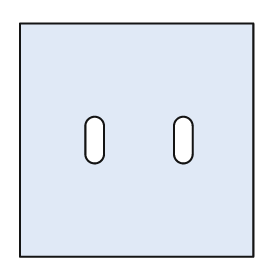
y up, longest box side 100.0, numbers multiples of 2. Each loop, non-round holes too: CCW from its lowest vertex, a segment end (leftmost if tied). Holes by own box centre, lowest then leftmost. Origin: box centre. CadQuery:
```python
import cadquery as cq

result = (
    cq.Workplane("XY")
    .moveTo(-50.0, -50.0)
    .lineTo(50.0, -50.0)
    .lineTo(50.0, 50.0)
    .lineTo(-50.0, 50.0)
    .close()
    .moveTo(-22.0, -6.0)
    .threePointArc((-18.0, -10.0), (-14.0, -6.0))
    .lineTo(-14.0, 6.0)
    .threePointArc((-18.0, 10.0), (-22.0, 6.0))
    .close()
    .moveTo(16.0, -6.0)
    .threePointArc((20.0, -10.0), (24.0, -6.0))
    .lineTo(24.0, 6.0)
    .threePointArc((20.0, 10.0), (16.0, 6.0))
    .close()
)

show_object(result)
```